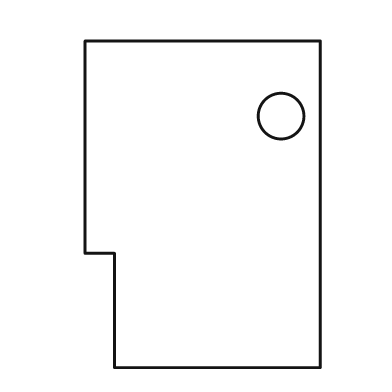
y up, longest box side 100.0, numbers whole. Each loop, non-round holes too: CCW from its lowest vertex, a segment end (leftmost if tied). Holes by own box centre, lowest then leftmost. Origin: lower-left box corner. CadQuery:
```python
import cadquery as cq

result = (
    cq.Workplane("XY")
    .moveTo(9.0, 0.0)
    .lineTo(72.0, 0.0)
    .lineTo(72.0, 100.0)
    .lineTo(0.0, 100.0)
    .lineTo(0.0, 35.0)
    .lineTo(9.0, 35.0)
    .close()
    .moveTo(60.0, 77.0)
    .circle(7.0)
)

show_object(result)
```